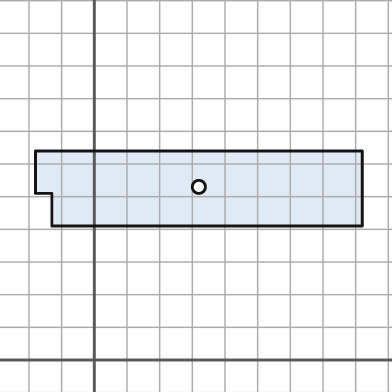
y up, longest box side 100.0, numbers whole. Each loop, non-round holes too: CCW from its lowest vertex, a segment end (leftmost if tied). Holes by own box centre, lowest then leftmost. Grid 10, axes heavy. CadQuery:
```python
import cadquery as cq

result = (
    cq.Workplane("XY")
    .moveTo(-13.0, 41.0)
    .lineTo(82.0, 41.0)
    .lineTo(82.0, 64.0)
    .lineTo(-18.0, 64.0)
    .lineTo(-18.0, 51.0)
    .lineTo(-13.0, 51.0)
    .close()
    .moveTo(32.0, 53.0)
    .circle(2.0)
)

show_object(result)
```